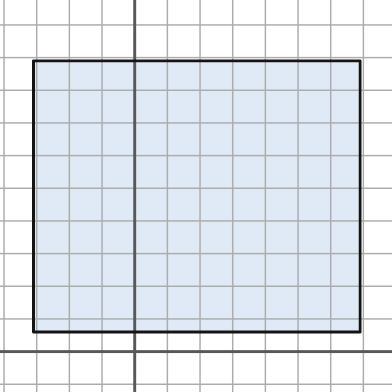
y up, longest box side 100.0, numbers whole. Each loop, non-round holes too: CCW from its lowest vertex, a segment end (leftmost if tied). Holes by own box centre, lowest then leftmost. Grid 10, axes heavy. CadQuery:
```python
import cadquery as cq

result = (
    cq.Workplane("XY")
    .moveTo(-31.0, 6.0)
    .lineTo(69.0, 6.0)
    .lineTo(69.0, 89.0)
    .lineTo(-31.0, 89.0)
    .close()
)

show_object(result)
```